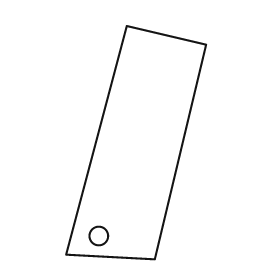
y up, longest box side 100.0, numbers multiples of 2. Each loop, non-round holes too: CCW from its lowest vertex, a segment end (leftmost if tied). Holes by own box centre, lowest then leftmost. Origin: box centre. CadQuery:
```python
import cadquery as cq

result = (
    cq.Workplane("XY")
    .moveTo(8.0, -50.0)
    .lineTo(30.0, 42.0)
    .lineTo(-4.0, 50.0)
    .lineTo(-30.0, -48.0)
    .close()
    .moveTo(-16.0, -40.0)
    .circle(4.0)
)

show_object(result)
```